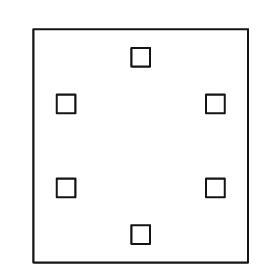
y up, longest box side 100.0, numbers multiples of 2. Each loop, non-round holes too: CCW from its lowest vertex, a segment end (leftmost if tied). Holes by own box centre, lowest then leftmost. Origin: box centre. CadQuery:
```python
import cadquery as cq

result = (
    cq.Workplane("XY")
    .moveTo(-46.0, -50.0)
    .lineTo(46.0, -50.0)
    .lineTo(46.0, 50.0)
    .lineTo(-46.0, 50.0)
    .close()
    .moveTo(-4.0, -42.0)
    .lineTo(4.0, -42.0)
    .lineTo(4.0, -34.0)
    .lineTo(-4.0, -34.0)
    .close()
    .moveTo(-36.0, -22.0)
    .lineTo(-28.0, -22.0)
    .lineTo(-28.0, -14.0)
    .lineTo(-36.0, -14.0)
    .close()
    .moveTo(28.0, -22.0)
    .lineTo(36.0, -22.0)
    .lineTo(36.0, -14.0)
    .lineTo(28.0, -14.0)
    .close()
    .moveTo(-36.0, 14.0)
    .lineTo(-28.0, 14.0)
    .lineTo(-28.0, 22.0)
    .lineTo(-36.0, 22.0)
    .close()
    .moveTo(28.0, 14.0)
    .lineTo(36.0, 14.0)
    .lineTo(36.0, 22.0)
    .lineTo(28.0, 22.0)
    .close()
    .moveTo(-4.0, 34.0)
    .lineTo(4.0, 34.0)
    .lineTo(4.0, 42.0)
    .lineTo(-4.0, 42.0)
    .close()
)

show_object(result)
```